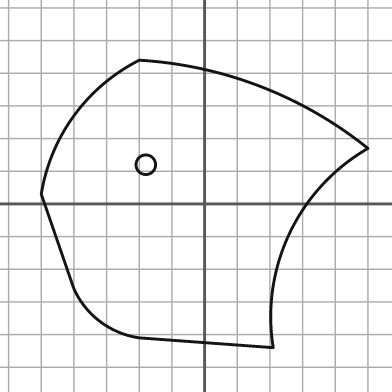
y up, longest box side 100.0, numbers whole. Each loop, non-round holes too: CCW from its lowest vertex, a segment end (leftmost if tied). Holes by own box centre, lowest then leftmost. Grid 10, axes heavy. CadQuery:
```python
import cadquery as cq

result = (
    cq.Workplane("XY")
    .moveTo(21.0, -44.0)
    .threePointArc((26.0, -9.0), (50.0, 17.0))
    .threePointArc((17.0, 36.0), (-20.0, 44.0))
    .threePointArc((-40.0, 27.0), (-50.0, 3.0))
    .lineTo(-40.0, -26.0)
    .threePointArc((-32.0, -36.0), (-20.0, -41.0))
    .close()
    .moveTo(-18.0, 12.0)
    .circle(3.0)
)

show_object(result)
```